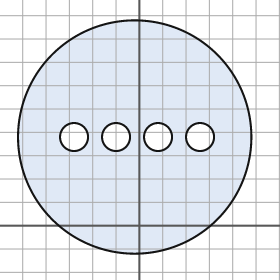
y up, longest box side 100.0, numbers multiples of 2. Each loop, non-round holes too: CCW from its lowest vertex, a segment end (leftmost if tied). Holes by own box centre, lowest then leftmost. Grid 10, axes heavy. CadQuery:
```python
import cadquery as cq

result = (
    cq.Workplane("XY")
    .moveTo(-2.0, 38.0)
    .circle(50.0)
    .moveTo(-28.0, 38.0)
    .circle(6.0)
    .moveTo(-10.0, 38.0)
    .circle(6.0)
    .moveTo(8.0, 38.0)
    .circle(6.0)
    .moveTo(26.0, 38.0)
    .circle(6.0)
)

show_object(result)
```